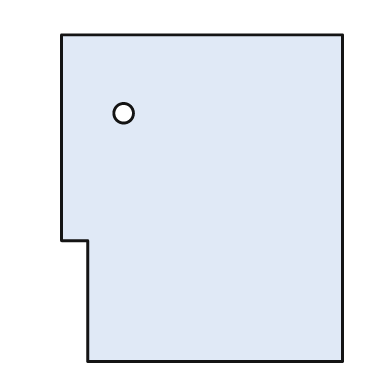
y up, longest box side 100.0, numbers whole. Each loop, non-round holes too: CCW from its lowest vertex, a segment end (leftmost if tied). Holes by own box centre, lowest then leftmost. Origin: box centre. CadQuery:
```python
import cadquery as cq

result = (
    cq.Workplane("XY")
    .moveTo(-35.0, -50.0)
    .lineTo(43.0, -50.0)
    .lineTo(43.0, 50.0)
    .lineTo(-43.0, 50.0)
    .lineTo(-43.0, -13.0)
    .lineTo(-35.0, -13.0)
    .close()
    .moveTo(-24.0, 26.0)
    .circle(3.0)
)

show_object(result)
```